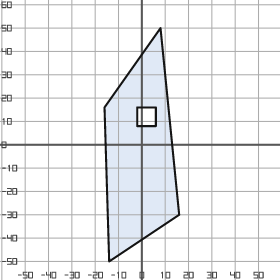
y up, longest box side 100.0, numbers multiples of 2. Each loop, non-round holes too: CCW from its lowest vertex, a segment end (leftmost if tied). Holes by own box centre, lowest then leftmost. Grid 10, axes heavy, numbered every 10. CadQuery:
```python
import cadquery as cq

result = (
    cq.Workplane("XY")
    .moveTo(-14.0, -50.0)
    .lineTo(16.0, -30.0)
    .lineTo(8.0, 50.0)
    .lineTo(-16.0, 16.0)
    .close()
    .moveTo(-2.0, 8.0)
    .lineTo(6.0, 8.0)
    .lineTo(6.0, 16.0)
    .lineTo(-2.0, 16.0)
    .close()
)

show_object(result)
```